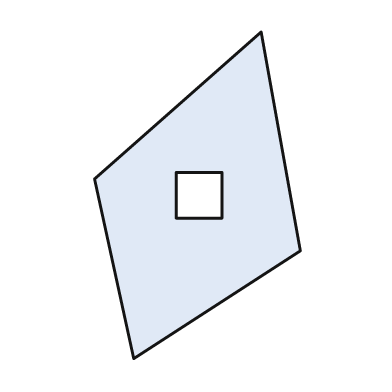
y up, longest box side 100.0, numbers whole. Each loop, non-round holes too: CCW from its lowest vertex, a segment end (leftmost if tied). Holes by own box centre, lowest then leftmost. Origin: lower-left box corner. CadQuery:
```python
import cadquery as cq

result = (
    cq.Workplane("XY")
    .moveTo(12.0, 0.0)
    .lineTo(63.0, 33.0)
    .lineTo(51.0, 100.0)
    .lineTo(0.0, 55.0)
    .close()
    .moveTo(25.0, 43.0)
    .lineTo(39.0, 43.0)
    .lineTo(39.0, 57.0)
    .lineTo(25.0, 57.0)
    .close()
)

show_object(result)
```